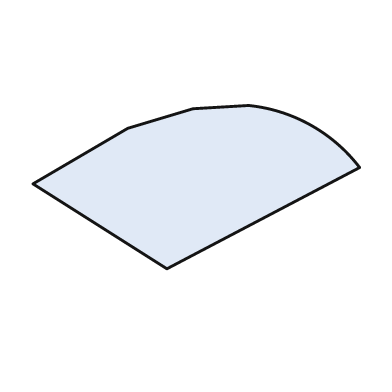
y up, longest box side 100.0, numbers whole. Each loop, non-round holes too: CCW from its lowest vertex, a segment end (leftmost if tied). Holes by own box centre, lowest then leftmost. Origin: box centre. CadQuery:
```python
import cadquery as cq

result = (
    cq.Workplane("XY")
    .moveTo(-9.0, -25.0)
    .lineTo(50.0, 6.0)
    .threePointArc((35.0, 19.0), (16.0, 25.0))
    .lineTo(-1.0, 24.0)
    .lineTo(-21.0, 18.0)
    .lineTo(-50.0, 1.0)
    .close()
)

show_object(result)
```